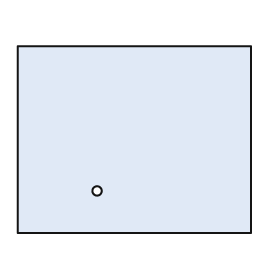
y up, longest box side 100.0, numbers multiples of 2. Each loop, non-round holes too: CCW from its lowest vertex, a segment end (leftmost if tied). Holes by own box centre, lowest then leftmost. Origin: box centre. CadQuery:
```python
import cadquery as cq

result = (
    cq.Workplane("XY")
    .moveTo(-50.0, -40.0)
    .lineTo(50.0, -40.0)
    .lineTo(50.0, 40.0)
    .lineTo(-50.0, 40.0)
    .close()
    .moveTo(-16.0, -22.0)
    .circle(2.0)
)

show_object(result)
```